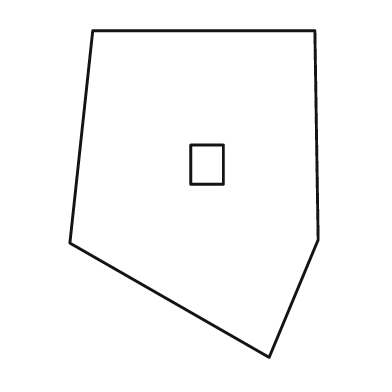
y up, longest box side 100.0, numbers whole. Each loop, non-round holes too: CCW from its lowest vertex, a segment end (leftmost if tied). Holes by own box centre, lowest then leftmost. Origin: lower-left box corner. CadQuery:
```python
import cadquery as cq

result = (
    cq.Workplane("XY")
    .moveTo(61.0, 0.0)
    .lineTo(76.0, 36.0)
    .lineTo(75.0, 100.0)
    .lineTo(7.0, 100.0)
    .lineTo(0.0, 35.0)
    .close()
    .moveTo(37.0, 53.0)
    .lineTo(47.0, 53.0)
    .lineTo(47.0, 65.0)
    .lineTo(37.0, 65.0)
    .close()
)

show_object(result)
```